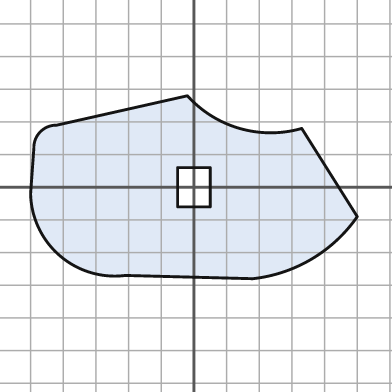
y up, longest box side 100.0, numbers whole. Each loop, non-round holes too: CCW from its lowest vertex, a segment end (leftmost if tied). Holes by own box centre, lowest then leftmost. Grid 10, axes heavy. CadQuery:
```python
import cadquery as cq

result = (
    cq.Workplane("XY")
    .moveTo(18.0, -28.0)
    .threePointArc((36.0, -22.0), (50.0, -9.0))
    .lineTo(33.0, 18.0)
    .threePointArc((14.0, 18.0), (-2.0, 28.0))
    .lineTo(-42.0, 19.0)
    .threePointArc((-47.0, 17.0), (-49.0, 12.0))
    .lineTo(-50.0, -2.0)
    .threePointArc((-41.0, -21.0), (-21.0, -27.0))
    .close()
    .moveTo(-5.0, -6.0)
    .lineTo(5.0, -6.0)
    .lineTo(5.0, 6.0)
    .lineTo(-5.0, 6.0)
    .close()
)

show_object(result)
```